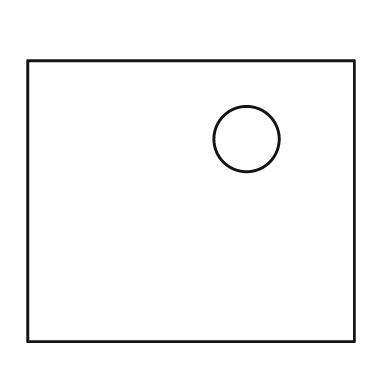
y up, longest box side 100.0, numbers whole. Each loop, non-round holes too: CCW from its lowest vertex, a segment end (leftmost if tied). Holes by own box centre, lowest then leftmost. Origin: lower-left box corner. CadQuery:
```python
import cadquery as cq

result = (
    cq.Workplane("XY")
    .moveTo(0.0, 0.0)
    .lineTo(100.0, 0.0)
    .lineTo(100.0, 86.0)
    .lineTo(0.0, 86.0)
    .close()
    .moveTo(67.0, 62.0)
    .circle(10.0)
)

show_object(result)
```